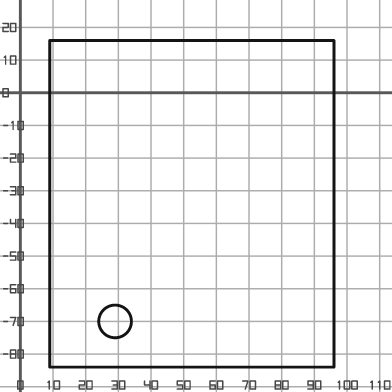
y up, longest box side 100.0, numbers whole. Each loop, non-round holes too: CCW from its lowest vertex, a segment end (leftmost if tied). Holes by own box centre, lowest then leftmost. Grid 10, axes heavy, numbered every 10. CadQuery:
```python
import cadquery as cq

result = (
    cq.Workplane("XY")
    .moveTo(9.0, -84.0)
    .lineTo(96.0, -84.0)
    .lineTo(96.0, 16.0)
    .lineTo(9.0, 16.0)
    .close()
    .moveTo(29.0, -70.0)
    .circle(5.0)
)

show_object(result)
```